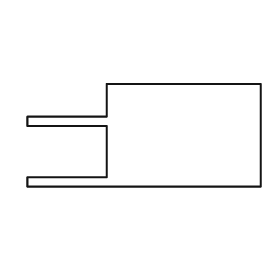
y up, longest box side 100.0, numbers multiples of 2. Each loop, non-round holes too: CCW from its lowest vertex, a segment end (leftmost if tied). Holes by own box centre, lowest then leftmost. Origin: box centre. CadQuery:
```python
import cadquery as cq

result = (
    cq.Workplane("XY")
    .moveTo(-50.0, -22.0)
    .lineTo(50.0, -22.0)
    .lineTo(50.0, 22.0)
    .lineTo(-16.0, 22.0)
    .lineTo(-16.0, 8.0)
    .lineTo(-50.0, 8.0)
    .lineTo(-50.0, 4.0)
    .lineTo(-16.0, 4.0)
    .lineTo(-16.0, -18.0)
    .lineTo(-50.0, -18.0)
    .close()
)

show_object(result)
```